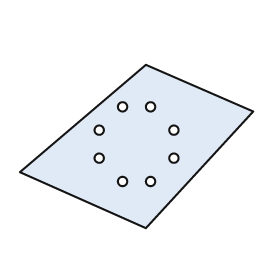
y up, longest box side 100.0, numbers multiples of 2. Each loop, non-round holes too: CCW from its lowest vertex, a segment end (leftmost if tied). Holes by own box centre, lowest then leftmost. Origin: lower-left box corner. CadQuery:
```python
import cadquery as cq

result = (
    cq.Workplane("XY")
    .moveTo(54.0, 0.0)
    .lineTo(100.0, 50.0)
    .lineTo(54.0, 70.0)
    .lineTo(0.0, 24.0)
    .close()
    .moveTo(44.0, 20.0)
    .circle(2.0)
    .moveTo(56.0, 20.0)
    .circle(2.0)
    .moveTo(34.0, 30.0)
    .circle(2.0)
    .moveTo(66.0, 30.0)
    .circle(2.0)
    .moveTo(34.0, 42.0)
    .circle(2.0)
    .moveTo(66.0, 42.0)
    .circle(2.0)
    .moveTo(44.0, 52.0)
    .circle(2.0)
    .moveTo(56.0, 52.0)
    .circle(2.0)
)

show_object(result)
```